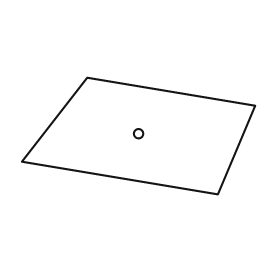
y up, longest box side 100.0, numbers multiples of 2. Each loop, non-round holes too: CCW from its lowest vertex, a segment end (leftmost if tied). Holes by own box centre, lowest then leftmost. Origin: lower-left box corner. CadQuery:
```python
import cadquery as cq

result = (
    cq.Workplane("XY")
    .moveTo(84.0, 0.0)
    .lineTo(100.0, 38.0)
    .lineTo(28.0, 50.0)
    .lineTo(0.0, 14.0)
    .close()
    .moveTo(50.0, 26.0)
    .circle(2.0)
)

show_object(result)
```